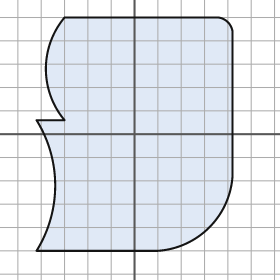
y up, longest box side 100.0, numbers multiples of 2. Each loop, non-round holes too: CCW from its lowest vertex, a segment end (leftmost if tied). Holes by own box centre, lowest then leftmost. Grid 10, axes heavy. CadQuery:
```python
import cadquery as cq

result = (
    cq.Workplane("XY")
    .moveTo(-42.0, -50.0)
    .lineTo(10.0, -50.0)
    .threePointArc((32.0, -40.0), (42.0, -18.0))
    .lineTo(42.0, 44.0)
    .threePointArc((40.0, 48.0), (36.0, 50.0))
    .lineTo(-30.0, 50.0)
    .threePointArc((-38.0, 28.0), (-30.0, 6.0))
    .lineTo(-42.0, 6.0)
    .threePointArc((-34.0, -22.0), (-42.0, -50.0))
    .close()
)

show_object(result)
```